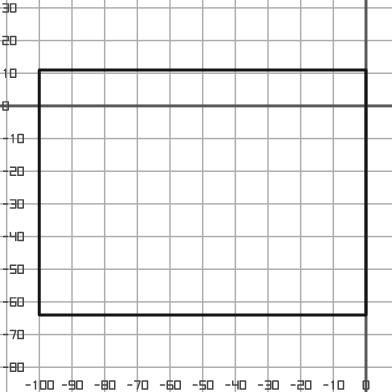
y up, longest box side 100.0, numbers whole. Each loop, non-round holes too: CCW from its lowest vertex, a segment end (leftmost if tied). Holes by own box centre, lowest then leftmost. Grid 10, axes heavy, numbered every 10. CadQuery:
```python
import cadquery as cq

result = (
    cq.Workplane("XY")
    .moveTo(-100.0, -64.0)
    .lineTo(0.0, -64.0)
    .lineTo(0.0, 11.0)
    .lineTo(-100.0, 11.0)
    .close()
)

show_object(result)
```